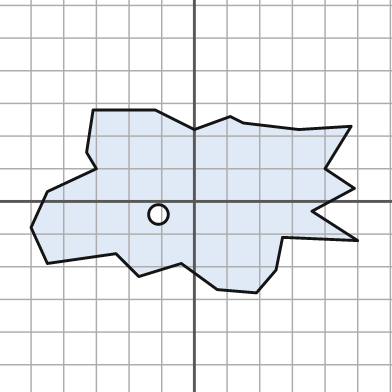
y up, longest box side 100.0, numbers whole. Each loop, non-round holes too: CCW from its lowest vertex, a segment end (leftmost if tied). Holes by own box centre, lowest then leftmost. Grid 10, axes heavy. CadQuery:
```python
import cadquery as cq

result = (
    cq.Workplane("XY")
    .moveTo(19.0, -28.0)
    .lineTo(25.0, -21.0)
    .lineTo(27.0, -11.0)
    .lineTo(50.0, -12.0)
    .lineTo(36.0, -3.0)
    .lineTo(49.0, 4.0)
    .lineTo(40.0, 10.0)
    .lineTo(48.0, 23.0)
    .lineTo(32.0, 22.0)
    .lineTo(15.0, 24.0)
    .lineTo(11.0, 26.0)
    .lineTo(0.0, 22.0)
    .lineTo(-12.0, 28.0)
    .lineTo(-31.0, 28.0)
    .lineTo(-33.0, 15.0)
    .lineTo(-30.0, 10.0)
    .lineTo(-45.0, 3.0)
    .lineTo(-50.0, -8.0)
    .lineTo(-45.0, -19.0)
    .lineTo(-24.0, -16.0)
    .lineTo(-17.0, -23.0)
    .lineTo(-4.0, -19.0)
    .lineTo(7.0, -27.0)
    .close()
    .moveTo(-11.0, -4.0)
    .circle(3.0)
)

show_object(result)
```